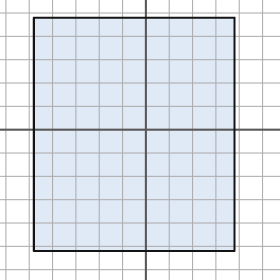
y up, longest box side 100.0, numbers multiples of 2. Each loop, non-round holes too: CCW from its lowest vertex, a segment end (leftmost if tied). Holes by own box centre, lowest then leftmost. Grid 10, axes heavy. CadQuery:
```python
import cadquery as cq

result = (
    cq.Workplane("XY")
    .moveTo(-48.0, -52.0)
    .lineTo(38.0, -52.0)
    .lineTo(38.0, 48.0)
    .lineTo(-48.0, 48.0)
    .close()
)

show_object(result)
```